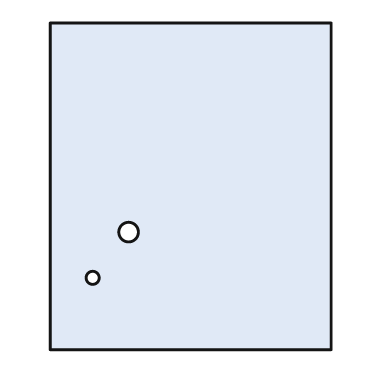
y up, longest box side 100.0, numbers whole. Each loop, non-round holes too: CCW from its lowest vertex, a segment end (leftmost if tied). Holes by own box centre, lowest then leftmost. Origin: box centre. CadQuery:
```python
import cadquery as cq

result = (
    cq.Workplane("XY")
    .moveTo(-43.0, -50.0)
    .lineTo(43.0, -50.0)
    .lineTo(43.0, 50.0)
    .lineTo(-43.0, 50.0)
    .close()
    .moveTo(-30.0, -28.0)
    .circle(2.0)
    .moveTo(-19.0, -14.0)
    .circle(3.0)
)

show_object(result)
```